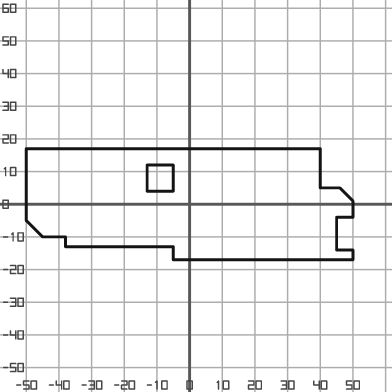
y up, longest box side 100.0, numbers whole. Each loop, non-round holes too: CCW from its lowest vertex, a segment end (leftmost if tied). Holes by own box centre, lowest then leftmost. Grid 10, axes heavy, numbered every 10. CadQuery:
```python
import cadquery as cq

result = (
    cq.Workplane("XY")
    .moveTo(-5.0, -17.0)
    .lineTo(50.0, -17.0)
    .lineTo(50.0, -14.0)
    .lineTo(45.0, -14.0)
    .lineTo(45.0, -4.0)
    .lineTo(50.0, -4.0)
    .lineTo(50.0, 1.0)
    .lineTo(46.0, 5.0)
    .lineTo(40.0, 5.0)
    .lineTo(40.0, 17.0)
    .lineTo(-50.0, 17.0)
    .lineTo(-50.0, -5.0)
    .lineTo(-45.0, -10.0)
    .lineTo(-38.0, -10.0)
    .lineTo(-38.0, -13.0)
    .lineTo(-5.0, -13.0)
    .close()
    .moveTo(-13.0, 4.0)
    .lineTo(-5.0, 4.0)
    .lineTo(-5.0, 12.0)
    .lineTo(-13.0, 12.0)
    .close()
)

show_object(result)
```